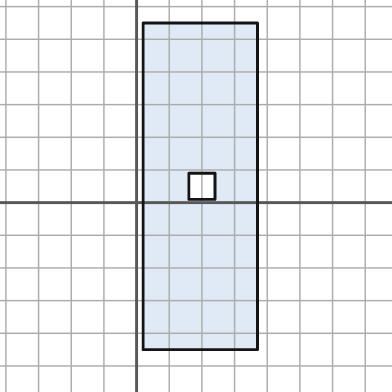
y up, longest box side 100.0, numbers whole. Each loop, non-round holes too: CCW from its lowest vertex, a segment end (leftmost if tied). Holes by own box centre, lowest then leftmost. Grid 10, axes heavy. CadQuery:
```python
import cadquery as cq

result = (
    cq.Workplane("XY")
    .moveTo(2.0, -45.0)
    .lineTo(37.0, -45.0)
    .lineTo(37.0, 55.0)
    .lineTo(2.0, 55.0)
    .close()
    .moveTo(16.0, 1.0)
    .lineTo(24.0, 1.0)
    .lineTo(24.0, 9.0)
    .lineTo(16.0, 9.0)
    .close()
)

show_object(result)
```